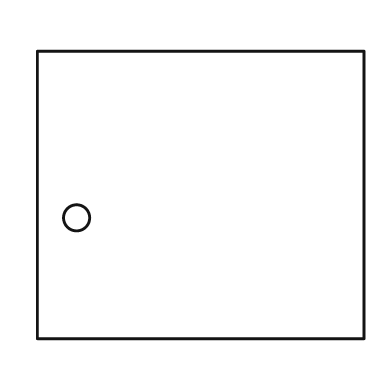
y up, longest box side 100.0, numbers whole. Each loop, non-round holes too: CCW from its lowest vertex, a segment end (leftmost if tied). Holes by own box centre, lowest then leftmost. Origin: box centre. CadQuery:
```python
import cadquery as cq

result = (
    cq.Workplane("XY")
    .moveTo(-50.0, -44.0)
    .lineTo(50.0, -44.0)
    .lineTo(50.0, 44.0)
    .lineTo(-50.0, 44.0)
    .close()
    .moveTo(-38.0, -7.0)
    .circle(4.0)
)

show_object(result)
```